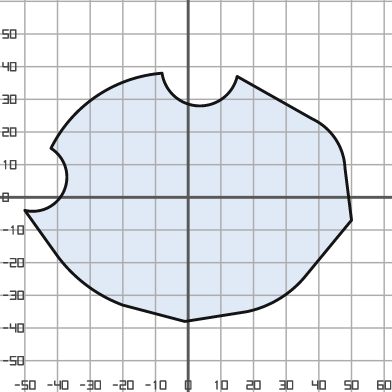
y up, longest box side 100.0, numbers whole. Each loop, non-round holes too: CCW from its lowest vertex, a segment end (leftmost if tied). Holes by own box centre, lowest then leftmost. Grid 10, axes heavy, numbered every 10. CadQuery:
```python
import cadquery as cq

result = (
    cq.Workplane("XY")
    .moveTo(-1.0, -38.0)
    .lineTo(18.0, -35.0)
    .threePointArc((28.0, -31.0), (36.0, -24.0))
    .lineTo(50.0, -7.0)
    .lineTo(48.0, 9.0)
    .threePointArc((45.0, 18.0), (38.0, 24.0))
    .lineTo(15.0, 37.0)
    .threePointArc((3.0, 28.0), (-8.0, 38.0))
    .threePointArc((-28.0, 31.0), (-42.0, 15.0))
    .threePointArc((-38.0, 2.0), (-50.0, -4.0))
    .lineTo(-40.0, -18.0)
    .threePointArc((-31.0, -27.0), (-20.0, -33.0))
    .close()
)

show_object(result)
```